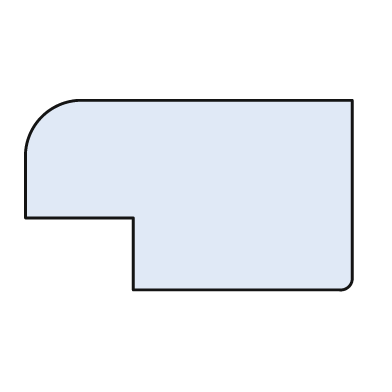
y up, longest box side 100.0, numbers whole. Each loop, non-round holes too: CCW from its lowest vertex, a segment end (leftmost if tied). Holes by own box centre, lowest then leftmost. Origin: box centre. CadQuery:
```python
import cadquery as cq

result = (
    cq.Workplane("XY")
    .moveTo(-17.0, -29.0)
    .lineTo(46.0, -29.0)
    .threePointArc((49.0, -28.0), (50.0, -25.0))
    .lineTo(50.0, 29.0)
    .lineTo(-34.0, 29.0)
    .threePointArc((-45.0, 24.0), (-50.0, 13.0))
    .lineTo(-50.0, -7.0)
    .lineTo(-17.0, -7.0)
    .close()
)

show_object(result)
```